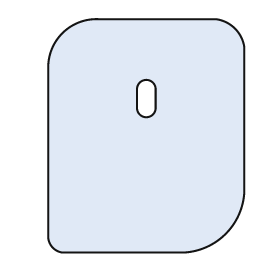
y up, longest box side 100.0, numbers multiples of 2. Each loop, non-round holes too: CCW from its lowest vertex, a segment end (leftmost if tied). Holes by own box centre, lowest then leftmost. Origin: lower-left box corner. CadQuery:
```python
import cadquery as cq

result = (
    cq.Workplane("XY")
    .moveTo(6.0, 0.0)
    .lineTo(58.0, 0.0)
    .threePointArc((76.0, 8.0), (84.0, 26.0))
    .lineTo(84.0, 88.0)
    .threePointArc((80.0, 96.0), (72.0, 100.0))
    .lineTo(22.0, 100.0)
    .threePointArc((6.0, 94.0), (0.0, 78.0))
    .lineTo(0.0, 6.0)
    .threePointArc((2.0, 2.0), (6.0, 0.0))
    .close()
    .moveTo(38.0, 62.0)
    .threePointArc((42.0, 58.0), (46.0, 62.0))
    .lineTo(46.0, 70.0)
    .threePointArc((42.0, 74.0), (38.0, 70.0))
    .close()
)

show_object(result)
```